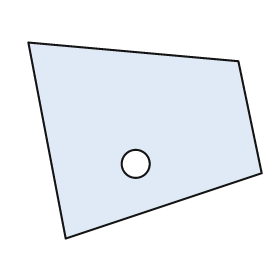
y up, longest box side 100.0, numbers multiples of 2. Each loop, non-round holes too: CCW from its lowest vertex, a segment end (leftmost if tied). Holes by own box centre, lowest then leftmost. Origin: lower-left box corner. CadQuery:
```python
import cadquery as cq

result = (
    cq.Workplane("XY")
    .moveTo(16.0, 0.0)
    .lineTo(100.0, 28.0)
    .lineTo(90.0, 76.0)
    .lineTo(0.0, 84.0)
    .close()
    .moveTo(46.0, 32.0)
    .circle(6.0)
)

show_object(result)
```